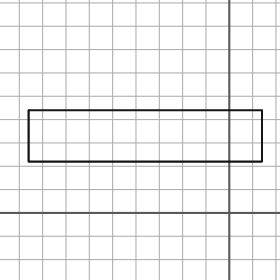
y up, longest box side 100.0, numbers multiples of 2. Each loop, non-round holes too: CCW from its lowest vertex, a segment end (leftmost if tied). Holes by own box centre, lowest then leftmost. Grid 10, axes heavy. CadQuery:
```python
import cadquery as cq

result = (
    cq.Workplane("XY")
    .moveTo(-86.0, 22.0)
    .lineTo(14.0, 22.0)
    .lineTo(14.0, 44.0)
    .lineTo(-86.0, 44.0)
    .close()
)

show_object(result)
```